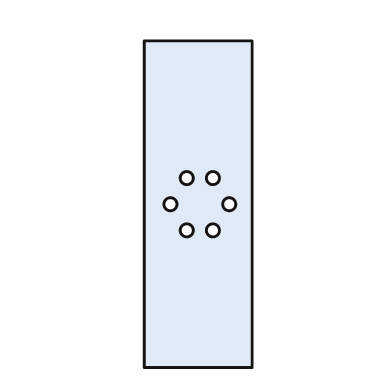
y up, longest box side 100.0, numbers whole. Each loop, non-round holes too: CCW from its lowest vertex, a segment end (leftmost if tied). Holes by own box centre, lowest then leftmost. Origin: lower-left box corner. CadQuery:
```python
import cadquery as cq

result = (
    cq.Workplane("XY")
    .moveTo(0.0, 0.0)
    .lineTo(33.0, 0.0)
    .lineTo(33.0, 100.0)
    .lineTo(0.0, 100.0)
    .close()
    .moveTo(13.0, 42.0)
    .circle(2.0)
    .moveTo(21.0, 42.0)
    .circle(2.0)
    .moveTo(8.0, 50.0)
    .circle(2.0)
    .moveTo(26.0, 50.0)
    .circle(2.0)
    .moveTo(13.0, 58.0)
    .circle(2.0)
    .moveTo(21.0, 58.0)
    .circle(2.0)
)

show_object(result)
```